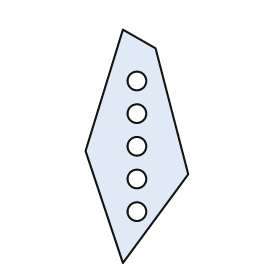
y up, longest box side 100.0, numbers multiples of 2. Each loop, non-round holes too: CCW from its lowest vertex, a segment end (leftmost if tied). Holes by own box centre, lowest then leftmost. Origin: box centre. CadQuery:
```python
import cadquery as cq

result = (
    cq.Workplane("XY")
    .moveTo(-6.0, -50.0)
    .lineTo(22.0, -12.0)
    .lineTo(8.0, 42.0)
    .lineTo(-6.0, 50.0)
    .lineTo(-22.0, -2.0)
    .close()
    .moveTo(0.0, -28.0)
    .circle(4.0)
    .moveTo(0.0, -14.0)
    .circle(4.0)
    .moveTo(0.0, 0.0)
    .circle(4.0)
    .moveTo(0.0, 14.0)
    .circle(4.0)
    .moveTo(0.0, 28.0)
    .circle(4.0)
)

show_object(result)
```